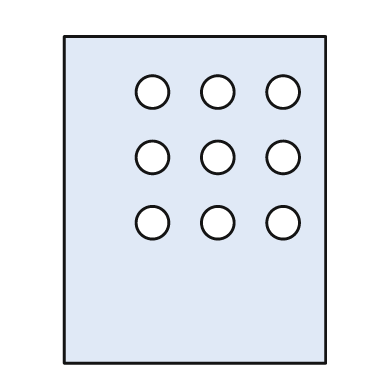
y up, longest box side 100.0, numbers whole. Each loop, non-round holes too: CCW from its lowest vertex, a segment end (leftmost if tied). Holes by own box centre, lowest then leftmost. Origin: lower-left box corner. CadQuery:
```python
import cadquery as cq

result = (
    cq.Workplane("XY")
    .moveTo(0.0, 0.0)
    .lineTo(80.0, 0.0)
    .lineTo(80.0, 100.0)
    .lineTo(0.0, 100.0)
    .close()
    .moveTo(27.0, 43.0)
    .circle(5.0)
    .moveTo(47.0, 43.0)
    .circle(5.0)
    .moveTo(67.0, 43.0)
    .circle(5.0)
    .moveTo(27.0, 63.0)
    .circle(5.0)
    .moveTo(47.0, 63.0)
    .circle(5.0)
    .moveTo(67.0, 63.0)
    .circle(5.0)
    .moveTo(27.0, 83.0)
    .circle(5.0)
    .moveTo(47.0, 83.0)
    .circle(5.0)
    .moveTo(67.0, 83.0)
    .circle(5.0)
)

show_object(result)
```